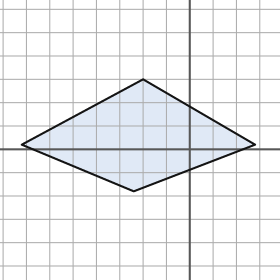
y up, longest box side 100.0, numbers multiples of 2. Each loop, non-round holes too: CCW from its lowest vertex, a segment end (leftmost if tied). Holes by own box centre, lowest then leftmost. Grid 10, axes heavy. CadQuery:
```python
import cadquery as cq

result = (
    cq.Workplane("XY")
    .moveTo(-24.0, -18.0)
    .lineTo(28.0, 2.0)
    .lineTo(-20.0, 30.0)
    .lineTo(-72.0, 2.0)
    .close()
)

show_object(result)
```